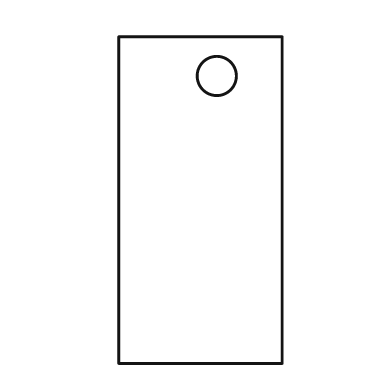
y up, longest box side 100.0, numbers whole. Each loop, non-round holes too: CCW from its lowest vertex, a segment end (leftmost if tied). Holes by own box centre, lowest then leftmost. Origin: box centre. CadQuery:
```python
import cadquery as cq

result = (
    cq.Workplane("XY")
    .moveTo(-25.0, -50.0)
    .lineTo(25.0, -50.0)
    .lineTo(25.0, 50.0)
    .lineTo(-25.0, 50.0)
    .close()
    .moveTo(5.0, 38.0)
    .circle(6.0)
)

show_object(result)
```